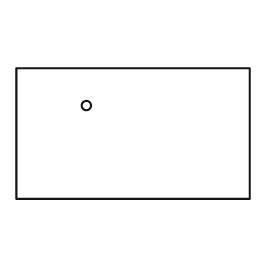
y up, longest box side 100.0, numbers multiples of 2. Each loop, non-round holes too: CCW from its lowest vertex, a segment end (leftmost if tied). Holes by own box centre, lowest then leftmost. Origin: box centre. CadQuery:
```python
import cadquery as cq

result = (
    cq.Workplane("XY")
    .moveTo(-50.0, -28.0)
    .lineTo(50.0, -28.0)
    .lineTo(50.0, 28.0)
    .lineTo(-50.0, 28.0)
    .close()
    .moveTo(-20.0, 12.0)
    .circle(2.0)
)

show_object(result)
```